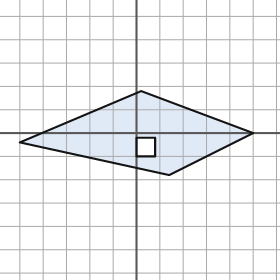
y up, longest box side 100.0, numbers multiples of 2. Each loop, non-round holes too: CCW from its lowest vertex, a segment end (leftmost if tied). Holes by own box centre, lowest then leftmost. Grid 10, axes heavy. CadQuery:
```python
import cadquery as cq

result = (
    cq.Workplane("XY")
    .moveTo(14.0, -18.0)
    .lineTo(50.0, 0.0)
    .lineTo(2.0, 18.0)
    .lineTo(-50.0, -4.0)
    .close()
    .moveTo(0.0, -10.0)
    .lineTo(8.0, -10.0)
    .lineTo(8.0, -2.0)
    .lineTo(0.0, -2.0)
    .close()
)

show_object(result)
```